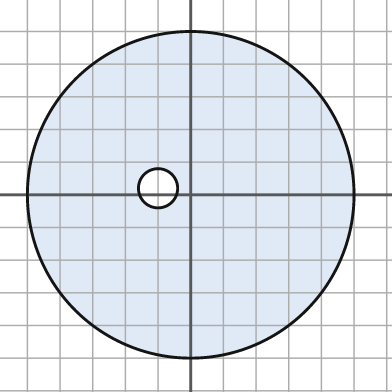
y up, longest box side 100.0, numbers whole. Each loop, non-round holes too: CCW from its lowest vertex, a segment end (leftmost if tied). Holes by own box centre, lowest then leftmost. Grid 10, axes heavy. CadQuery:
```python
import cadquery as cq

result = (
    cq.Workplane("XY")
    .moveTo(0.0, 0.0)
    .circle(50.0)
    .moveTo(-10.0, 2.0)
    .circle(6.0)
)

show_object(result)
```